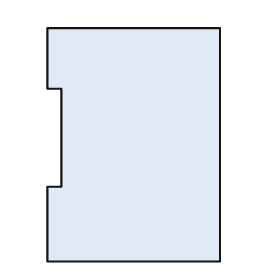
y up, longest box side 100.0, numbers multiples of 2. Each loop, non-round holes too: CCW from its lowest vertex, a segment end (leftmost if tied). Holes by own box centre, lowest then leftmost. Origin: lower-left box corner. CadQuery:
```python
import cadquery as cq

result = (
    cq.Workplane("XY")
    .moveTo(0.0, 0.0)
    .lineTo(74.0, 0.0)
    .lineTo(74.0, 100.0)
    .lineTo(0.0, 100.0)
    .lineTo(0.0, 74.0)
    .lineTo(6.0, 74.0)
    .lineTo(6.0, 32.0)
    .lineTo(0.0, 32.0)
    .close()
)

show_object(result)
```